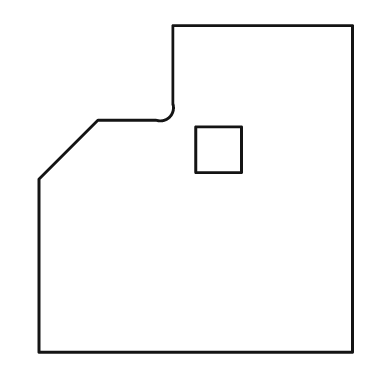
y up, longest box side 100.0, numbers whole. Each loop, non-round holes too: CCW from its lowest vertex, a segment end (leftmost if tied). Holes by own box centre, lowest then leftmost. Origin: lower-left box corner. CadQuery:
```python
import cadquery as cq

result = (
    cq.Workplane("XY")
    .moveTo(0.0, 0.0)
    .lineTo(96.0, 0.0)
    .lineTo(96.0, 100.0)
    .lineTo(41.0, 100.0)
    .lineTo(41.0, 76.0)
    .threePointArc((40.0, 72.0), (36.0, 71.0))
    .lineTo(18.0, 71.0)
    .lineTo(0.0, 53.0)
    .close()
    .moveTo(48.0, 55.0)
    .lineTo(62.0, 55.0)
    .lineTo(62.0, 69.0)
    .lineTo(48.0, 69.0)
    .close()
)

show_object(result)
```